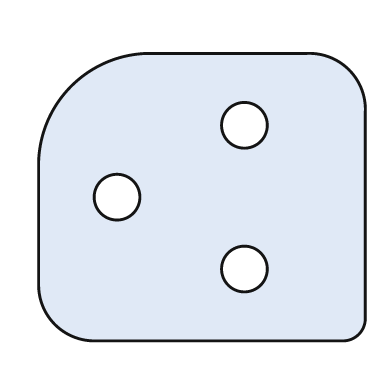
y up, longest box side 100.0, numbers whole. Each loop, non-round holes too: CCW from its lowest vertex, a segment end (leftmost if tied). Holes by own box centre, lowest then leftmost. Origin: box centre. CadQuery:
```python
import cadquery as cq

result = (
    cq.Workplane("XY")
    .moveTo(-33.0, -44.0)
    .lineTo(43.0, -44.0)
    .threePointArc((48.0, -42.0), (50.0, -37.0))
    .lineTo(50.0, 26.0)
    .threePointArc((45.0, 39.0), (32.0, 44.0))
    .lineTo(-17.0, 44.0)
    .threePointArc((-40.0, 34.0), (-50.0, 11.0))
    .lineTo(-50.0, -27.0)
    .threePointArc((-45.0, -39.0), (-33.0, -44.0))
    .close()
    .moveTo(13.0, -22.0)
    .circle(7.0)
    .moveTo(-26.0, 0.0)
    .circle(7.0)
    .moveTo(13.0, 22.0)
    .circle(7.0)
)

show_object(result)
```